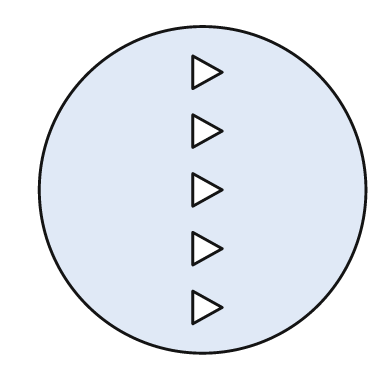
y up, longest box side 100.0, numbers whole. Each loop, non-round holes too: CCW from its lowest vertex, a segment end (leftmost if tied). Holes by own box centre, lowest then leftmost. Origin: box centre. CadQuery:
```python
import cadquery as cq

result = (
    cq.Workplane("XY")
    .moveTo(0.0, 0.0)
    .circle(50.0)
    .moveTo(-3.0, -41.0)
    .lineTo(6.0, -36.0)
    .lineTo(-3.0, -31.0)
    .close()
    .moveTo(-3.0, -23.0)
    .lineTo(6.0, -18.0)
    .lineTo(-3.0, -13.0)
    .close()
    .moveTo(-3.0, -5.0)
    .lineTo(6.0, 0.0)
    .lineTo(-3.0, 5.0)
    .close()
    .moveTo(-3.0, 13.0)
    .lineTo(6.0, 18.0)
    .lineTo(-3.0, 23.0)
    .close()
    .moveTo(-3.0, 31.0)
    .lineTo(6.0, 36.0)
    .lineTo(-3.0, 41.0)
    .close()
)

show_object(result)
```